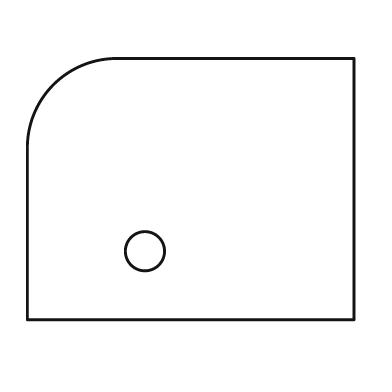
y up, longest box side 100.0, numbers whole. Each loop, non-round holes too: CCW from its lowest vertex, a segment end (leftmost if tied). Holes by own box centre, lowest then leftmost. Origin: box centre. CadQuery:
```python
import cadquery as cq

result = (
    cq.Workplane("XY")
    .moveTo(-50.0, -40.0)
    .lineTo(50.0, -40.0)
    .lineTo(50.0, 40.0)
    .lineTo(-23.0, 40.0)
    .threePointArc((-42.0, 32.0), (-50.0, 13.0))
    .close()
    .moveTo(-14.0, -19.0)
    .circle(6.0)
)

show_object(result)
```